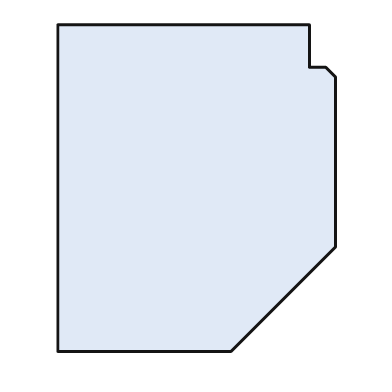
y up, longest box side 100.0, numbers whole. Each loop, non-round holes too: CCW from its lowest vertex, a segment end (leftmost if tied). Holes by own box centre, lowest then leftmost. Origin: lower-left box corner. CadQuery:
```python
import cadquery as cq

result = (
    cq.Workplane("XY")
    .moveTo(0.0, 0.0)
    .lineTo(53.0, 0.0)
    .lineTo(85.0, 32.0)
    .lineTo(85.0, 84.0)
    .lineTo(82.0, 87.0)
    .lineTo(77.0, 87.0)
    .lineTo(77.0, 100.0)
    .lineTo(0.0, 100.0)
    .close()
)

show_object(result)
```